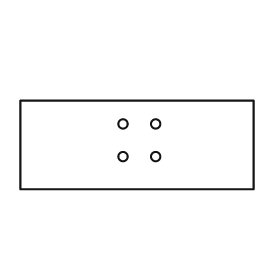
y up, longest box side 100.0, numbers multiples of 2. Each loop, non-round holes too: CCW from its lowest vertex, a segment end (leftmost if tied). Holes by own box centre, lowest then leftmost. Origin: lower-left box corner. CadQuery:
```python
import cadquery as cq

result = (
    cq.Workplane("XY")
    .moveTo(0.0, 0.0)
    .lineTo(100.0, 0.0)
    .lineTo(100.0, 38.0)
    .lineTo(0.0, 38.0)
    .close()
    .moveTo(44.0, 14.0)
    .circle(2.0)
    .moveTo(58.0, 14.0)
    .circle(2.0)
    .moveTo(44.0, 28.0)
    .circle(2.0)
    .moveTo(58.0, 28.0)
    .circle(2.0)
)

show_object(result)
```